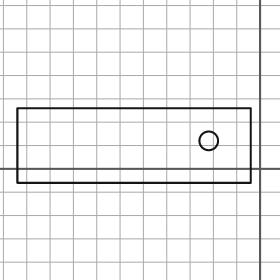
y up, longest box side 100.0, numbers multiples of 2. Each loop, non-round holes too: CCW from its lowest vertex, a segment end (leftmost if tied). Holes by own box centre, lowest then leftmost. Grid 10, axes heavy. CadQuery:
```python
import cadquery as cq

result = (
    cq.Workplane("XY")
    .moveTo(-104.0, -6.0)
    .lineTo(-4.0, -6.0)
    .lineTo(-4.0, 26.0)
    .lineTo(-104.0, 26.0)
    .close()
    .moveTo(-22.0, 12.0)
    .circle(4.0)
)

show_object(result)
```